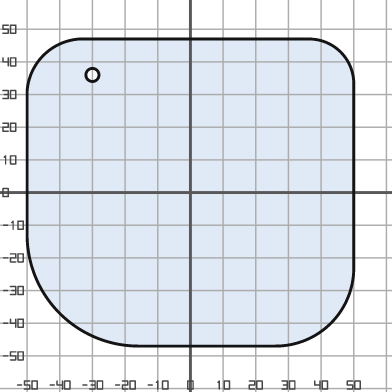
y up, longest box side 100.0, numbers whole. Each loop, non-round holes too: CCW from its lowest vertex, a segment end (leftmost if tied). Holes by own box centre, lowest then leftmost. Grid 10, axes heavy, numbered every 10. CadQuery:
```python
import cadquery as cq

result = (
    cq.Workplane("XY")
    .moveTo(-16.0, -47.0)
    .lineTo(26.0, -47.0)
    .threePointArc((43.0, -40.0), (50.0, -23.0))
    .lineTo(50.0, 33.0)
    .threePointArc((46.0, 43.0), (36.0, 47.0))
    .lineTo(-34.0, 47.0)
    .threePointArc((-45.0, 42.0), (-50.0, 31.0))
    .lineTo(-50.0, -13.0)
    .threePointArc((-40.0, -37.0), (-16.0, -47.0))
    .close()
    .moveTo(-30.0, 36.0)
    .circle(2.0)
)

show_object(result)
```